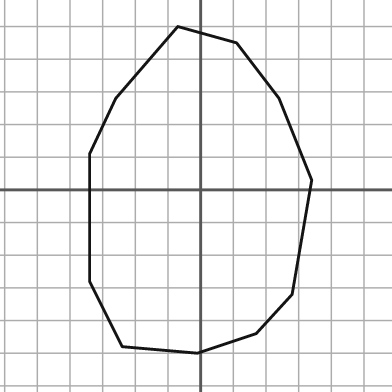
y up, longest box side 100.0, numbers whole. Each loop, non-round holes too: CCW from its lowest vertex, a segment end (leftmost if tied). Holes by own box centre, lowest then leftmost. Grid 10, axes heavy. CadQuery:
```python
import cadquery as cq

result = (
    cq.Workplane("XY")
    .moveTo(-1.0, -50.0)
    .lineTo(17.0, -44.0)
    .lineTo(28.0, -32.0)
    .lineTo(34.0, 3.0)
    .lineTo(24.0, 28.0)
    .lineTo(11.0, 45.0)
    .lineTo(-7.0, 50.0)
    .lineTo(-26.0, 28.0)
    .lineTo(-34.0, 11.0)
    .lineTo(-34.0, -28.0)
    .lineTo(-24.0, -48.0)
    .close()
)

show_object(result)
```